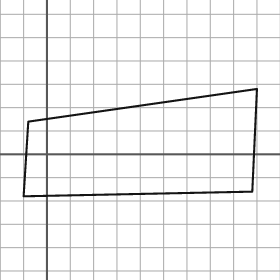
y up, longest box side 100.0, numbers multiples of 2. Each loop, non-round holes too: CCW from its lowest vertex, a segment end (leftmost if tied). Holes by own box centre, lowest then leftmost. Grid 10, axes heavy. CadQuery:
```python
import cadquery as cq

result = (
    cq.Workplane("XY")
    .moveTo(-10.0, -18.0)
    .lineTo(88.0, -16.0)
    .lineTo(90.0, 28.0)
    .lineTo(-8.0, 14.0)
    .close()
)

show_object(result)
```